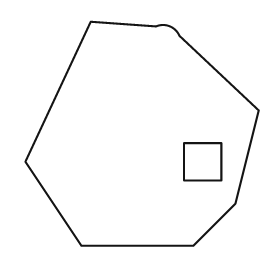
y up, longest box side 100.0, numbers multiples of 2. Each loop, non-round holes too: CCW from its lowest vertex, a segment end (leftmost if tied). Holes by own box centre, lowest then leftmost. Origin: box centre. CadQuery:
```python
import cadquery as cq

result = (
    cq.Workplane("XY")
    .moveTo(-26.0, -48.0)
    .lineTo(22.0, -48.0)
    .lineTo(40.0, -30.0)
    .lineTo(50.0, 10.0)
    .lineTo(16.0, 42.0)
    .threePointArc((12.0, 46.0), (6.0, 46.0))
    .lineTo(-22.0, 48.0)
    .lineTo(-50.0, -12.0)
    .close()
    .moveTo(18.0, -20.0)
    .lineTo(34.0, -20.0)
    .lineTo(34.0, -4.0)
    .lineTo(18.0, -4.0)
    .close()
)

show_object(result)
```